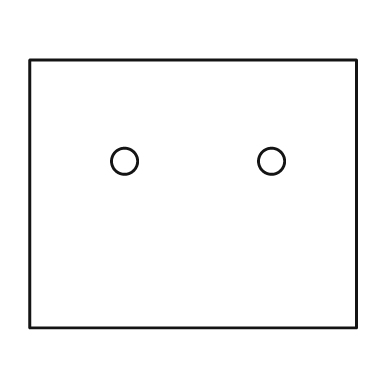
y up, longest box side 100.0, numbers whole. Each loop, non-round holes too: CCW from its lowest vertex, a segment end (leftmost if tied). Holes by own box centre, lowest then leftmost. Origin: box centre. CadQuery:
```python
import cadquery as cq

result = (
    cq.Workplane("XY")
    .moveTo(-50.0, -41.0)
    .lineTo(50.0, -41.0)
    .lineTo(50.0, 41.0)
    .lineTo(-50.0, 41.0)
    .close()
    .moveTo(-21.0, 10.0)
    .circle(4.0)
    .moveTo(24.0, 10.0)
    .circle(4.0)
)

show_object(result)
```